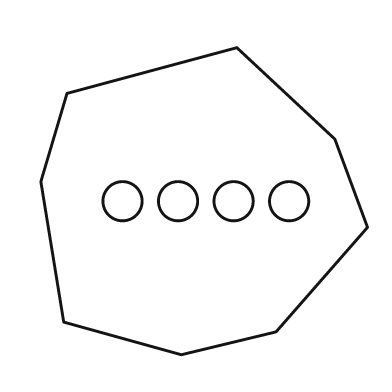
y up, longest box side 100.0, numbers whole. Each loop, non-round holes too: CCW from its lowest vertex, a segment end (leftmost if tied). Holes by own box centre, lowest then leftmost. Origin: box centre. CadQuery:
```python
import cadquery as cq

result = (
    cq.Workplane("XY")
    .moveTo(-7.0, -47.0)
    .lineTo(22.0, -40.0)
    .lineTo(50.0, -8.0)
    .lineTo(40.0, 19.0)
    .lineTo(10.0, 47.0)
    .lineTo(-42.0, 33.0)
    .lineTo(-50.0, 6.0)
    .lineTo(-43.0, -37.0)
    .close()
    .moveTo(-25.0, 0.0)
    .circle(6.0)
    .moveTo(-8.0, 0.0)
    .circle(6.0)
    .moveTo(9.0, 0.0)
    .circle(6.0)
    .moveTo(26.0, 0.0)
    .circle(6.0)
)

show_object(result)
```